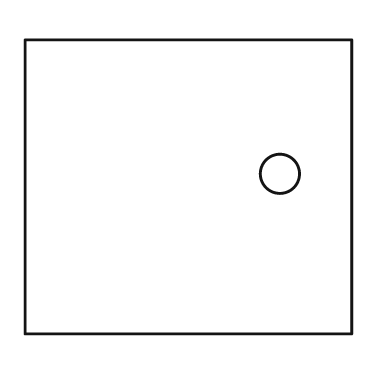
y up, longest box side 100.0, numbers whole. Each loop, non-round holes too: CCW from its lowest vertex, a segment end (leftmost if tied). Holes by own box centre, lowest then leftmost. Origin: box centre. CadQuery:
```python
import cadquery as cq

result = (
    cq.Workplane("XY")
    .moveTo(-50.0, -45.0)
    .lineTo(50.0, -45.0)
    .lineTo(50.0, 45.0)
    .lineTo(-50.0, 45.0)
    .close()
    .moveTo(28.0, 4.0)
    .circle(6.0)
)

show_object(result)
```